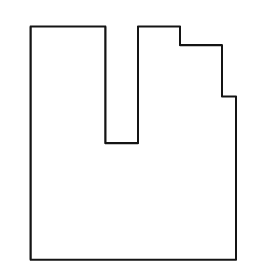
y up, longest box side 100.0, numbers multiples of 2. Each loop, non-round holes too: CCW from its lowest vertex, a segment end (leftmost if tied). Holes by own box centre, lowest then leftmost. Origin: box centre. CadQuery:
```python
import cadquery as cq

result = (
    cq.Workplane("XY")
    .moveTo(-44.0, -50.0)
    .lineTo(44.0, -50.0)
    .lineTo(44.0, 20.0)
    .lineTo(38.0, 20.0)
    .lineTo(38.0, 42.0)
    .lineTo(20.0, 42.0)
    .lineTo(20.0, 50.0)
    .lineTo(2.0, 50.0)
    .lineTo(2.0, 0.0)
    .lineTo(-12.0, 0.0)
    .lineTo(-12.0, 50.0)
    .lineTo(-44.0, 50.0)
    .close()
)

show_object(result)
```